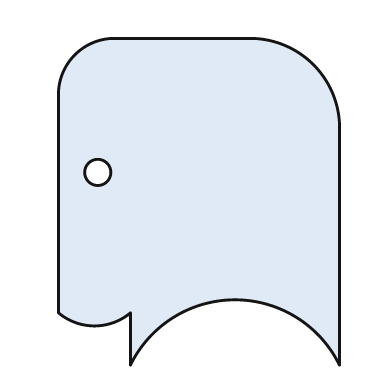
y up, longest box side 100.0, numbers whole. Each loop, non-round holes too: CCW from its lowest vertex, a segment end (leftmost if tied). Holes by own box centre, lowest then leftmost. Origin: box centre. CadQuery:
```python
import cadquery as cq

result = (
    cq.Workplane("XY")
    .moveTo(-21.0, -50.0)
    .threePointArc((11.0, -30.0), (43.0, -50.0))
    .lineTo(43.0, 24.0)
    .threePointArc((35.0, 42.0), (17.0, 50.0))
    .lineTo(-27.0, 50.0)
    .threePointArc((-38.0, 45.0), (-43.0, 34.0))
    .lineTo(-43.0, -34.0)
    .threePointArc((-32.0, -38.0), (-21.0, -34.0))
    .close()
    .moveTo(-31.0, 9.0)
    .circle(4.0)
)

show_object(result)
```